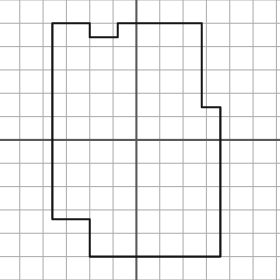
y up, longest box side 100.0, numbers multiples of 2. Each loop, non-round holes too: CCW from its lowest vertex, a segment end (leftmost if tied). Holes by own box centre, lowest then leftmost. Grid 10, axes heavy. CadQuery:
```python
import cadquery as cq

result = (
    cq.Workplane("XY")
    .moveTo(-20.0, -50.0)
    .lineTo(36.0, -50.0)
    .lineTo(36.0, 14.0)
    .lineTo(28.0, 14.0)
    .lineTo(28.0, 50.0)
    .lineTo(-8.0, 50.0)
    .lineTo(-8.0, 44.0)
    .lineTo(-20.0, 44.0)
    .lineTo(-20.0, 50.0)
    .lineTo(-36.0, 50.0)
    .lineTo(-36.0, -34.0)
    .lineTo(-20.0, -34.0)
    .close()
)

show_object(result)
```